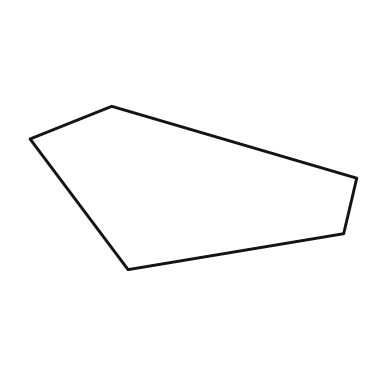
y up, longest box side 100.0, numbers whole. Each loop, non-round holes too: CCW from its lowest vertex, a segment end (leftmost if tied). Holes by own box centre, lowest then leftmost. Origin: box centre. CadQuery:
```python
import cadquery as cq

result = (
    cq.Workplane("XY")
    .moveTo(-20.0, -25.0)
    .lineTo(46.0, -14.0)
    .lineTo(50.0, 3.0)
    .lineTo(-25.0, 25.0)
    .lineTo(-50.0, 15.0)
    .close()
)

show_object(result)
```